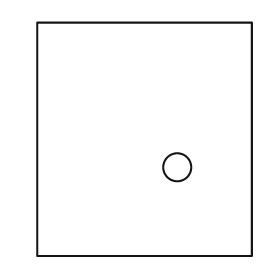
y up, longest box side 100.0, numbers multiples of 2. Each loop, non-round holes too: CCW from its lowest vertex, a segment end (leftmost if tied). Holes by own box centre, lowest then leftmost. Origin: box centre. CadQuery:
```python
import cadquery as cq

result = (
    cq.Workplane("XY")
    .moveTo(-46.0, -50.0)
    .lineTo(46.0, -50.0)
    .lineTo(46.0, 50.0)
    .lineTo(-46.0, 50.0)
    .close()
    .moveTo(14.0, -12.0)
    .circle(6.0)
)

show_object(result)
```